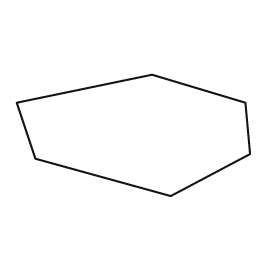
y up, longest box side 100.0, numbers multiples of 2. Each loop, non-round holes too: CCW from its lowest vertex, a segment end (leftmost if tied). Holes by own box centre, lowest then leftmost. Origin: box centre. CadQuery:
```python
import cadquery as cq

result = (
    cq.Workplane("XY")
    .moveTo(16.0, -26.0)
    .lineTo(50.0, -8.0)
    .lineTo(48.0, 14.0)
    .lineTo(8.0, 26.0)
    .lineTo(-50.0, 14.0)
    .lineTo(-42.0, -10.0)
    .close()
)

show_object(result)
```